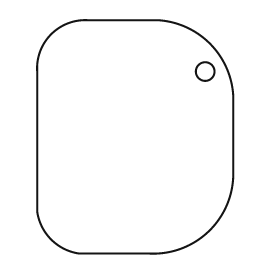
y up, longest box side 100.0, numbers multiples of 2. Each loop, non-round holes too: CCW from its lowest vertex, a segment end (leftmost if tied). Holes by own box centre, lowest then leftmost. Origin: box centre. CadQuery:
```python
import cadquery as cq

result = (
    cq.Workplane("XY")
    .moveTo(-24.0, -50.0)
    .lineTo(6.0, -50.0)
    .threePointArc((32.0, -40.0), (42.0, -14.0))
    .lineTo(42.0, 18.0)
    .threePointArc((32.0, 40.0), (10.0, 50.0))
    .lineTo(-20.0, 50.0)
    .threePointArc((-36.0, 44.0), (-42.0, 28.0))
    .lineTo(-42.0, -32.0)
    .threePointArc((-36.0, -44.0), (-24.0, -50.0))
    .close()
    .moveTo(30.0, 28.0)
    .circle(4.0)
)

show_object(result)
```